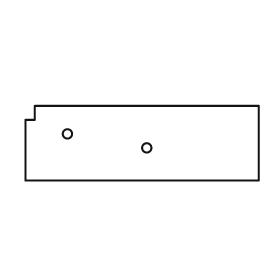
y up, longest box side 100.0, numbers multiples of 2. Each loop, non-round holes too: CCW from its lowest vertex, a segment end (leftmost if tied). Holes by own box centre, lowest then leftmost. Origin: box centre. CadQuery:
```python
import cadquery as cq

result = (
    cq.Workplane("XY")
    .moveTo(-50.0, -16.0)
    .lineTo(50.0, -16.0)
    .lineTo(50.0, 16.0)
    .lineTo(-46.0, 16.0)
    .lineTo(-46.0, 10.0)
    .lineTo(-50.0, 10.0)
    .close()
    .moveTo(2.0, -2.0)
    .circle(2.0)
    .moveTo(-32.0, 4.0)
    .circle(2.0)
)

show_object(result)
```